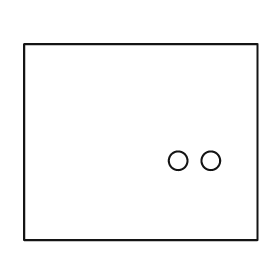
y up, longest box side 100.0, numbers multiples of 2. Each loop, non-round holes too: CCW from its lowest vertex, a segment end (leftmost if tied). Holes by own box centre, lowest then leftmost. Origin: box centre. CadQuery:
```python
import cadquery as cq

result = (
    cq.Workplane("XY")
    .moveTo(-50.0, -42.0)
    .lineTo(50.0, -42.0)
    .lineTo(50.0, 42.0)
    .lineTo(-50.0, 42.0)
    .close()
    .moveTo(16.0, -8.0)
    .circle(4.0)
    .moveTo(30.0, -8.0)
    .circle(4.0)
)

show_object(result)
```